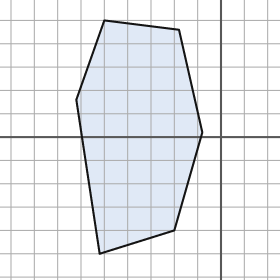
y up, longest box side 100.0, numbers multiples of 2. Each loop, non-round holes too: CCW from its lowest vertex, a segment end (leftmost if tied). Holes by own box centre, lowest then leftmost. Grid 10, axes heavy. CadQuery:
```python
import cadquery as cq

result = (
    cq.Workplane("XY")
    .moveTo(-52.0, -50.0)
    .lineTo(-20.0, -40.0)
    .lineTo(-8.0, 2.0)
    .lineTo(-18.0, 46.0)
    .lineTo(-50.0, 50.0)
    .lineTo(-62.0, 16.0)
    .close()
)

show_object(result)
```